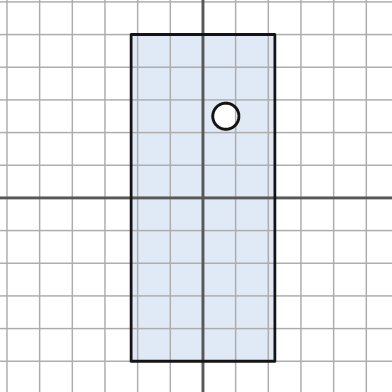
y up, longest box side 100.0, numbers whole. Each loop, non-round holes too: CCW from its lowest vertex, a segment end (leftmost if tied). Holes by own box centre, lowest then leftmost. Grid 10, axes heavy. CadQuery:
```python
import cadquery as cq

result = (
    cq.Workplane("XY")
    .moveTo(-22.0, -50.0)
    .lineTo(22.0, -50.0)
    .lineTo(22.0, 50.0)
    .lineTo(-22.0, 50.0)
    .close()
    .moveTo(7.0, 25.0)
    .circle(4.0)
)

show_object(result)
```